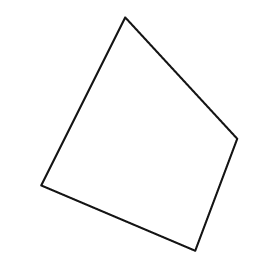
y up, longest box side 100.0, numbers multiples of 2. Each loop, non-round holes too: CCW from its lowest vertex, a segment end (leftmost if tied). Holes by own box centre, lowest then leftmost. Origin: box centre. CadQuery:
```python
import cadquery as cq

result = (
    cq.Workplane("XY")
    .moveTo(24.0, -50.0)
    .lineTo(42.0, -2.0)
    .lineTo(-6.0, 50.0)
    .lineTo(-42.0, -22.0)
    .close()
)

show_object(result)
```